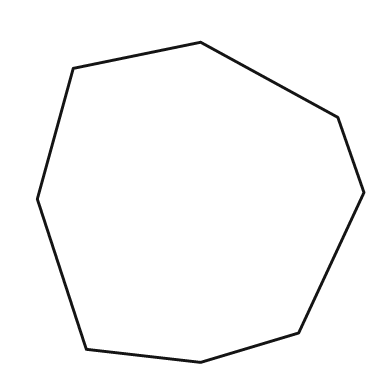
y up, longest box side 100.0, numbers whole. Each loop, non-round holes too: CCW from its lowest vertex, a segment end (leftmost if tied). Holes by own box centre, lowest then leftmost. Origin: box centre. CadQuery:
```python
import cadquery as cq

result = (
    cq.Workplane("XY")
    .moveTo(0.0, -49.0)
    .lineTo(30.0, -40.0)
    .lineTo(50.0, 3.0)
    .lineTo(42.0, 26.0)
    .lineTo(0.0, 49.0)
    .lineTo(-39.0, 41.0)
    .lineTo(-50.0, 1.0)
    .lineTo(-35.0, -45.0)
    .close()
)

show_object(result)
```